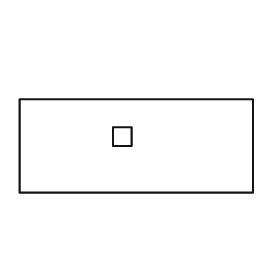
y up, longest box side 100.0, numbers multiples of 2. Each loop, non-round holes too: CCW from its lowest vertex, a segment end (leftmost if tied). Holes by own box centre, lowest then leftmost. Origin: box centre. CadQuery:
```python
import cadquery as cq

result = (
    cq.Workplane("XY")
    .moveTo(-50.0, -20.0)
    .lineTo(50.0, -20.0)
    .lineTo(50.0, 20.0)
    .lineTo(-50.0, 20.0)
    .close()
    .moveTo(-10.0, 0.0)
    .lineTo(-2.0, 0.0)
    .lineTo(-2.0, 8.0)
    .lineTo(-10.0, 8.0)
    .close()
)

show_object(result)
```